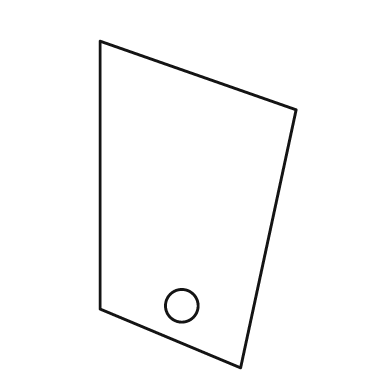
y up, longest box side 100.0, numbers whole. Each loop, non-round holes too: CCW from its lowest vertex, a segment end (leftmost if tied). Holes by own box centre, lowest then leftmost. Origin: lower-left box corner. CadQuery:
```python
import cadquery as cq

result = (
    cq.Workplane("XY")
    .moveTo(43.0, 0.0)
    .lineTo(60.0, 79.0)
    .lineTo(0.0, 100.0)
    .lineTo(0.0, 18.0)
    .close()
    .moveTo(25.0, 19.0)
    .circle(5.0)
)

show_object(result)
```